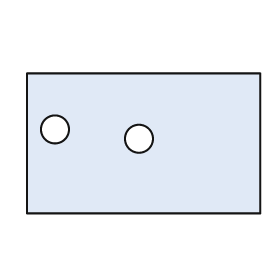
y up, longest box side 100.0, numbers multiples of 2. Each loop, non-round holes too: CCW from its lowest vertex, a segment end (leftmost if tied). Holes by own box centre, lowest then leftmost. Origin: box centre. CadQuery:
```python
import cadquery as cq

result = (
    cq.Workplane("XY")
    .moveTo(-50.0, -30.0)
    .lineTo(50.0, -30.0)
    .lineTo(50.0, 30.0)
    .lineTo(-50.0, 30.0)
    .close()
    .moveTo(-2.0, 2.0)
    .circle(6.0)
    .moveTo(-38.0, 6.0)
    .circle(6.0)
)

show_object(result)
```